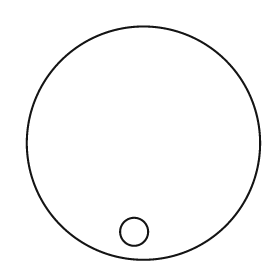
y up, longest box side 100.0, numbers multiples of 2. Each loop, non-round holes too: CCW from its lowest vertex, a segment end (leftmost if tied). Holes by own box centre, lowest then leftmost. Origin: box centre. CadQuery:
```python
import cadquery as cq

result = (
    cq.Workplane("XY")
    .moveTo(0.0, 0.0)
    .circle(50.0)
    .moveTo(-4.0, -38.0)
    .circle(6.0)
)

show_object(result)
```